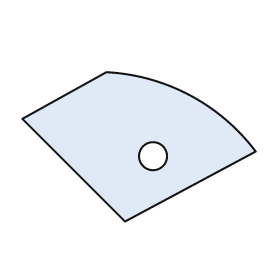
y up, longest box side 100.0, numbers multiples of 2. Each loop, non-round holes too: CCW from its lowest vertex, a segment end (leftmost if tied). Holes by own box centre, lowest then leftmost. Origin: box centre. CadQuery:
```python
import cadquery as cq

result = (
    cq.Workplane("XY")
    .moveTo(-6.0, -32.0)
    .lineTo(50.0, -2.0)
    .threePointArc((22.0, 22.0), (-14.0, 32.0))
    .lineTo(-50.0, 12.0)
    .close()
    .moveTo(6.0, -4.0)
    .circle(6.0)
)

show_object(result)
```